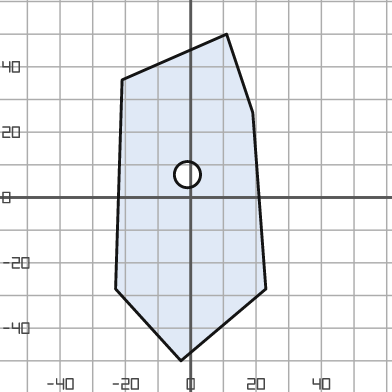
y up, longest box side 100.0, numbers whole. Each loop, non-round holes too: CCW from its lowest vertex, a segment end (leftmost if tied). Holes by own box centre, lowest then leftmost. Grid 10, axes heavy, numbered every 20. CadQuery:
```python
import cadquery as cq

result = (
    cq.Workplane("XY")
    .moveTo(-3.0, -50.0)
    .lineTo(23.0, -28.0)
    .lineTo(19.0, 26.0)
    .lineTo(11.0, 50.0)
    .lineTo(-21.0, 36.0)
    .lineTo(-23.0, -28.0)
    .close()
    .moveTo(-1.0, 7.0)
    .circle(4.0)
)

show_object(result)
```